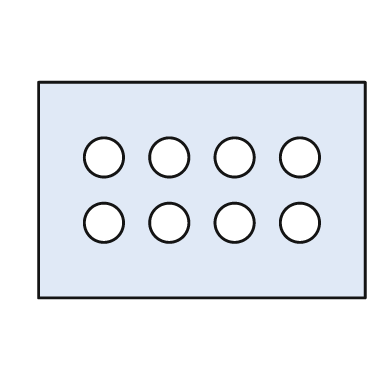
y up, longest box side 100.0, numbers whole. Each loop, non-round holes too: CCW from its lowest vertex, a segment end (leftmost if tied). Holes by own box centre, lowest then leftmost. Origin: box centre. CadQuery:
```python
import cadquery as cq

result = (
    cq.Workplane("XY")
    .moveTo(-50.0, -33.0)
    .lineTo(50.0, -33.0)
    .lineTo(50.0, 33.0)
    .lineTo(-50.0, 33.0)
    .close()
    .moveTo(-30.0, -10.0)
    .circle(6.0)
    .moveTo(-10.0, -10.0)
    .circle(6.0)
    .moveTo(10.0, -10.0)
    .circle(6.0)
    .moveTo(30.0, -10.0)
    .circle(6.0)
    .moveTo(-30.0, 10.0)
    .circle(6.0)
    .moveTo(-10.0, 10.0)
    .circle(6.0)
    .moveTo(10.0, 10.0)
    .circle(6.0)
    .moveTo(30.0, 10.0)
    .circle(6.0)
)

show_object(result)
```